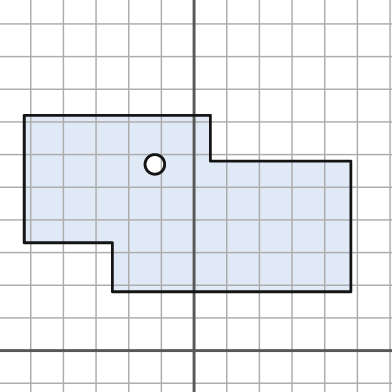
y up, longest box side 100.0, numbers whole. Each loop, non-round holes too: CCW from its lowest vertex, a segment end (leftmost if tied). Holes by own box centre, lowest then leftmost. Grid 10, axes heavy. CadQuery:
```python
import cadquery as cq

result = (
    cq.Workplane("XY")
    .moveTo(-25.0, 18.0)
    .lineTo(48.0, 18.0)
    .lineTo(48.0, 58.0)
    .lineTo(5.0, 58.0)
    .lineTo(5.0, 72.0)
    .lineTo(-52.0, 72.0)
    .lineTo(-52.0, 33.0)
    .lineTo(-25.0, 33.0)
    .close()
    .moveTo(-12.0, 57.0)
    .circle(3.0)
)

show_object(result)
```